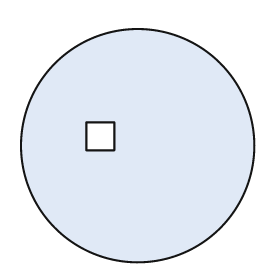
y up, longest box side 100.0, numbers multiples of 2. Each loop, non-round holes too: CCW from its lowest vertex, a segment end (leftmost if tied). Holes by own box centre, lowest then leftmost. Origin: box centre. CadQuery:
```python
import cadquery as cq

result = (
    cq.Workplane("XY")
    .moveTo(0.0, 0.0)
    .circle(50.0)
    .moveTo(-22.0, -2.0)
    .lineTo(-10.0, -2.0)
    .lineTo(-10.0, 10.0)
    .lineTo(-22.0, 10.0)
    .close()
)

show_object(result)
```